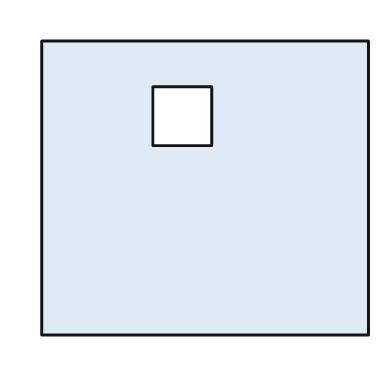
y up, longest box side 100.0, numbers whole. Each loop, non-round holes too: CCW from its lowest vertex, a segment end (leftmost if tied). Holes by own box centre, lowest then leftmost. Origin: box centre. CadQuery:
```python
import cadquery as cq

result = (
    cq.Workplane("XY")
    .moveTo(-50.0, -45.0)
    .lineTo(50.0, -45.0)
    .lineTo(50.0, 45.0)
    .lineTo(-50.0, 45.0)
    .close()
    .moveTo(-16.0, 13.0)
    .lineTo(2.0, 13.0)
    .lineTo(2.0, 31.0)
    .lineTo(-16.0, 31.0)
    .close()
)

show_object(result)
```